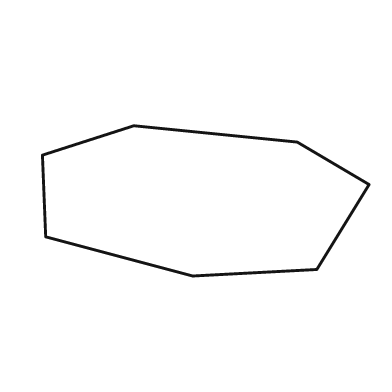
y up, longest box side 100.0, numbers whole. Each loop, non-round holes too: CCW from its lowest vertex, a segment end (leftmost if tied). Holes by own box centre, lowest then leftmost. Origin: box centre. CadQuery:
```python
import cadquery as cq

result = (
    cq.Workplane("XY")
    .moveTo(-4.0, -23.0)
    .lineTo(34.0, -21.0)
    .lineTo(50.0, 5.0)
    .lineTo(28.0, 18.0)
    .lineTo(-22.0, 23.0)
    .lineTo(-50.0, 14.0)
    .lineTo(-49.0, -11.0)
    .close()
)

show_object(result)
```